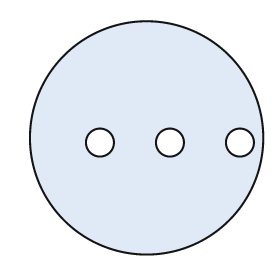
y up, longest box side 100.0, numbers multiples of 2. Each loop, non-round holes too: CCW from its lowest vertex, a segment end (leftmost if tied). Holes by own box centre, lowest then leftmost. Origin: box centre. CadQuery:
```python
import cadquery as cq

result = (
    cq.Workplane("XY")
    .moveTo(0.0, 0.0)
    .circle(50.0)
    .moveTo(-20.0, -2.0)
    .circle(6.0)
    .moveTo(10.0, -2.0)
    .circle(6.0)
    .moveTo(40.0, -2.0)
    .circle(6.0)
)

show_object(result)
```